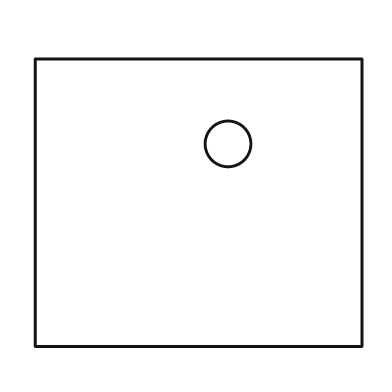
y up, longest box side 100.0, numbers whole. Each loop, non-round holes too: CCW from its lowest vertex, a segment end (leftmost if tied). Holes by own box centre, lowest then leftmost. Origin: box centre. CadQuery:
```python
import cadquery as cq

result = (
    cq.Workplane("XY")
    .moveTo(-50.0, -44.0)
    .lineTo(50.0, -44.0)
    .lineTo(50.0, 44.0)
    .lineTo(-50.0, 44.0)
    .close()
    .moveTo(9.0, 18.0)
    .circle(7.0)
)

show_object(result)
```